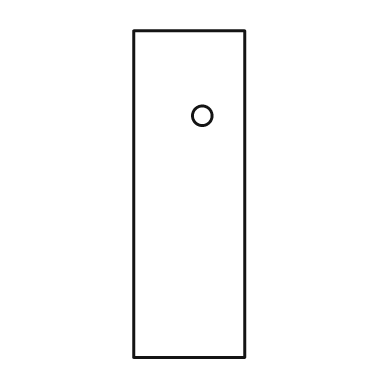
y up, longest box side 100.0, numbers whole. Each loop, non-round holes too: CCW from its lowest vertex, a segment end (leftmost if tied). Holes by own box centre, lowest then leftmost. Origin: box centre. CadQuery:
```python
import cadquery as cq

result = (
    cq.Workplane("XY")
    .moveTo(-17.0, -50.0)
    .lineTo(17.0, -50.0)
    .lineTo(17.0, 50.0)
    .lineTo(-17.0, 50.0)
    .close()
    .moveTo(4.0, 24.0)
    .circle(3.0)
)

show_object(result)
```